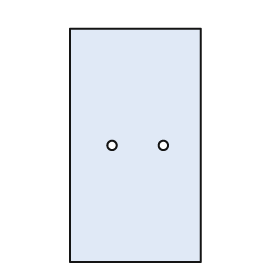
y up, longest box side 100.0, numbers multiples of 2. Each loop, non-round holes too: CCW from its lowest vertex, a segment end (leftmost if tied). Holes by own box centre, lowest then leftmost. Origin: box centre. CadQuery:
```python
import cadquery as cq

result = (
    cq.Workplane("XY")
    .moveTo(-28.0, -50.0)
    .lineTo(28.0, -50.0)
    .lineTo(28.0, 50.0)
    .lineTo(-28.0, 50.0)
    .close()
    .moveTo(-10.0, 0.0)
    .circle(2.0)
    .moveTo(12.0, 0.0)
    .circle(2.0)
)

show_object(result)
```